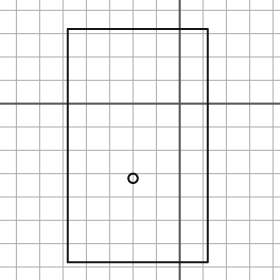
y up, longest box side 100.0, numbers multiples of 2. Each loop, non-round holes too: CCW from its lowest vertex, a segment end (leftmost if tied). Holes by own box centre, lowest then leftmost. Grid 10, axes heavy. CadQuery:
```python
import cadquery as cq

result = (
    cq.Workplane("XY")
    .moveTo(-48.0, -68.0)
    .lineTo(12.0, -68.0)
    .lineTo(12.0, 32.0)
    .lineTo(-48.0, 32.0)
    .close()
    .moveTo(-20.0, -32.0)
    .circle(2.0)
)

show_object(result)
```